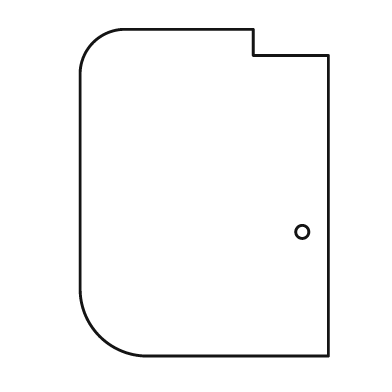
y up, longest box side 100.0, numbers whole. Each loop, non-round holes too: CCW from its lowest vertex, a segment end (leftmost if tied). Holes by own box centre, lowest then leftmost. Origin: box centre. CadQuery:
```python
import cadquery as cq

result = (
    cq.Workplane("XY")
    .moveTo(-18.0, -50.0)
    .lineTo(38.0, -50.0)
    .lineTo(38.0, 42.0)
    .lineTo(15.0, 42.0)
    .lineTo(15.0, 50.0)
    .lineTo(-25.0, 50.0)
    .threePointArc((-34.0, 46.0), (-38.0, 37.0))
    .lineTo(-38.0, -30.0)
    .threePointArc((-32.0, -44.0), (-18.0, -50.0))
    .close()
    .moveTo(30.0, -12.0)
    .circle(2.0)
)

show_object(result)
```